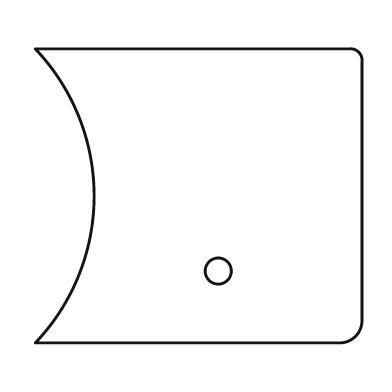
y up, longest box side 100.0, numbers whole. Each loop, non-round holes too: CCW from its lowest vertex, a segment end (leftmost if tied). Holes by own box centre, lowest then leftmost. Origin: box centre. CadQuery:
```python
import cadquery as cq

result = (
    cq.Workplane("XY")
    .moveTo(-50.0, -45.0)
    .lineTo(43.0, -45.0)
    .threePointArc((48.0, -43.0), (50.0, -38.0))
    .lineTo(50.0, 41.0)
    .threePointArc((49.0, 44.0), (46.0, 45.0))
    .lineTo(-50.0, 45.0)
    .threePointArc((-32.0, 0.0), (-50.0, -45.0))
    .close()
    .moveTo(6.0, -23.0)
    .circle(4.0)
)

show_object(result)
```